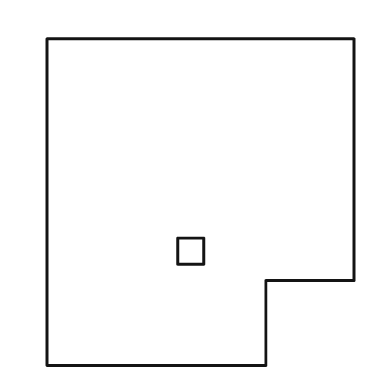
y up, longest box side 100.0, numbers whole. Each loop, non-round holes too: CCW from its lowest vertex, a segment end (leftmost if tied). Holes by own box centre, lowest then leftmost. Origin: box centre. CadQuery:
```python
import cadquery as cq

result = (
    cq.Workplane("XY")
    .moveTo(-47.0, -50.0)
    .lineTo(20.0, -50.0)
    .lineTo(20.0, -24.0)
    .lineTo(47.0, -24.0)
    .lineTo(47.0, 50.0)
    .lineTo(-47.0, 50.0)
    .close()
    .moveTo(-7.0, -19.0)
    .lineTo(1.0, -19.0)
    .lineTo(1.0, -11.0)
    .lineTo(-7.0, -11.0)
    .close()
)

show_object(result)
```